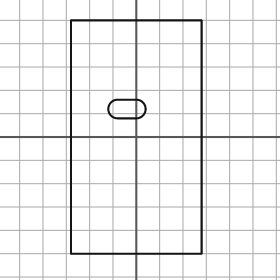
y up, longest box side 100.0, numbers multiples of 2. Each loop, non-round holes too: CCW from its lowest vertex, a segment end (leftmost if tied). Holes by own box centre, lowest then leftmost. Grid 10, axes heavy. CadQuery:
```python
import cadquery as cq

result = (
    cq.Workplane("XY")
    .moveTo(-28.0, -50.0)
    .lineTo(28.0, -50.0)
    .lineTo(28.0, 50.0)
    .lineTo(-28.0, 50.0)
    .close()
    .moveTo(-8.0, 8.0)
    .lineTo(0.0, 8.0)
    .threePointArc((4.0, 12.0), (0.0, 16.0))
    .lineTo(-8.0, 16.0)
    .threePointArc((-12.0, 12.0), (-8.0, 8.0))
    .close()
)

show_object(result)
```